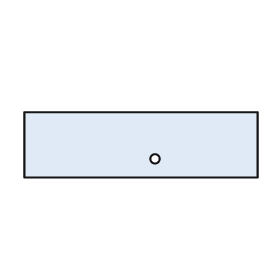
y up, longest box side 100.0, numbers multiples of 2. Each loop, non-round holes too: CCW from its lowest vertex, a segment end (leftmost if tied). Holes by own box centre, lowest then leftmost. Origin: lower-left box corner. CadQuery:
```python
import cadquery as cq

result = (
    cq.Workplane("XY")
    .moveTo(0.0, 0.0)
    .lineTo(100.0, 0.0)
    .lineTo(100.0, 28.0)
    .lineTo(0.0, 28.0)
    .close()
    .moveTo(56.0, 8.0)
    .circle(2.0)
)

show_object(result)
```